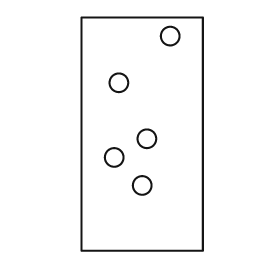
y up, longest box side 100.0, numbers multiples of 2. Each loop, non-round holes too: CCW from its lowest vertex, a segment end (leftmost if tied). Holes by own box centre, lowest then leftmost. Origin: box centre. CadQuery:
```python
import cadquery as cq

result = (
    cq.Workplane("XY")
    .moveTo(-26.0, -50.0)
    .lineTo(26.0, -50.0)
    .lineTo(26.0, 50.0)
    .lineTo(-26.0, 50.0)
    .close()
    .moveTo(0.0, -22.0)
    .circle(4.0)
    .moveTo(-12.0, -10.0)
    .circle(4.0)
    .moveTo(2.0, -2.0)
    .circle(4.0)
    .moveTo(-10.0, 22.0)
    .circle(4.0)
    .moveTo(12.0, 42.0)
    .circle(4.0)
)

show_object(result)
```